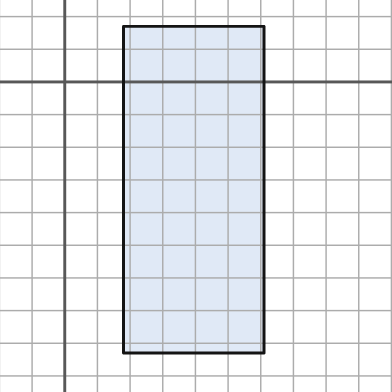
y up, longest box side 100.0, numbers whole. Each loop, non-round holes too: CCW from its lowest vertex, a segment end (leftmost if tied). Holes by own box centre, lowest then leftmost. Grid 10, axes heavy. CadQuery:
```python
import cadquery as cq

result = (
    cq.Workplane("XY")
    .moveTo(18.0, -83.0)
    .lineTo(61.0, -83.0)
    .lineTo(61.0, 17.0)
    .lineTo(18.0, 17.0)
    .close()
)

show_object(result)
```